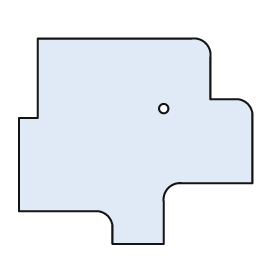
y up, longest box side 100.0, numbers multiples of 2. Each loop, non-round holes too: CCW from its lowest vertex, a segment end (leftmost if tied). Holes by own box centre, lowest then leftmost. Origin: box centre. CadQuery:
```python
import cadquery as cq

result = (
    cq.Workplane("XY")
    .moveTo(-10.0, -44.0)
    .lineTo(12.0, -44.0)
    .lineTo(12.0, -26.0)
    .threePointArc((14.0, -20.0), (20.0, -18.0))
    .lineTo(50.0, -18.0)
    .lineTo(50.0, 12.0)
    .threePointArc((48.0, 16.0), (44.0, 18.0))
    .lineTo(32.0, 18.0)
    .lineTo(32.0, 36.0)
    .threePointArc((30.0, 42.0), (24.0, 44.0))
    .lineTo(-42.0, 44.0)
    .lineTo(-42.0, 10.0)
    .lineTo(-50.0, 10.0)
    .lineTo(-50.0, -30.0)
    .lineTo(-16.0, -30.0)
    .threePointArc((-12.0, -32.0), (-10.0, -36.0))
    .close()
    .moveTo(12.0, 14.0)
    .circle(2.0)
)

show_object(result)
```